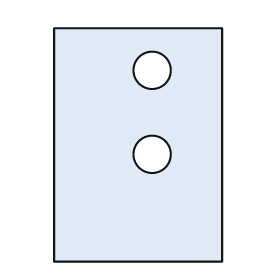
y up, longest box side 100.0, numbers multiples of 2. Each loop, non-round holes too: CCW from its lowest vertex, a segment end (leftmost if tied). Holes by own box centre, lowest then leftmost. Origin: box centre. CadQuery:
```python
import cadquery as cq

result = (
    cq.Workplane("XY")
    .moveTo(-36.0, -50.0)
    .lineTo(36.0, -50.0)
    .lineTo(36.0, 50.0)
    .lineTo(-36.0, 50.0)
    .close()
    .moveTo(6.0, -4.0)
    .circle(8.0)
    .moveTo(6.0, 32.0)
    .circle(8.0)
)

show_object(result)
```